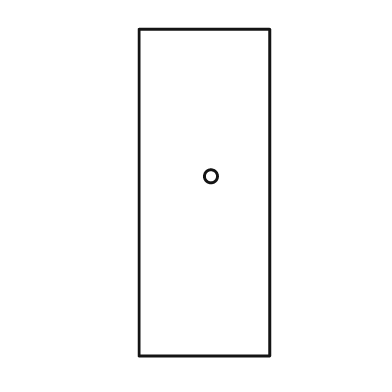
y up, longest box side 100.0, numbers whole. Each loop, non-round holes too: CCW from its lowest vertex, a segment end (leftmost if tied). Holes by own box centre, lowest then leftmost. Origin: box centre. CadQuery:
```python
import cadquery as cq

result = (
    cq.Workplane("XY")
    .moveTo(-20.0, -50.0)
    .lineTo(20.0, -50.0)
    .lineTo(20.0, 50.0)
    .lineTo(-20.0, 50.0)
    .close()
    .moveTo(2.0, 5.0)
    .circle(2.0)
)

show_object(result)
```